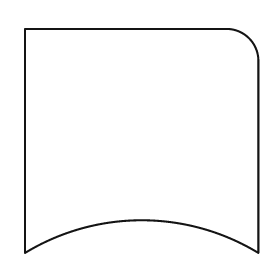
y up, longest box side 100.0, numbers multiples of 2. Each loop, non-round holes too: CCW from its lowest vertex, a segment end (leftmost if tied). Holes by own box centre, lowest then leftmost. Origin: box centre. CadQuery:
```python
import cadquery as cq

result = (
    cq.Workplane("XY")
    .moveTo(-50.0, -48.0)
    .threePointArc((0.0, -34.0), (50.0, -48.0))
    .lineTo(50.0, 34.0)
    .threePointArc((46.0, 44.0), (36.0, 48.0))
    .lineTo(-50.0, 48.0)
    .close()
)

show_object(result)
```